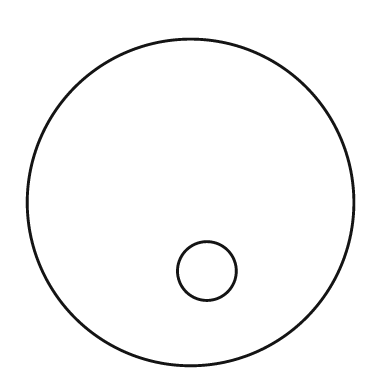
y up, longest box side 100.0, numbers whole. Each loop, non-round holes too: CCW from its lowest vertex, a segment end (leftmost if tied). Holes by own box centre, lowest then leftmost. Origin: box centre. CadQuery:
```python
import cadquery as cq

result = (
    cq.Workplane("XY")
    .moveTo(0.0, 0.0)
    .circle(50.0)
    .moveTo(5.0, -21.0)
    .circle(9.0)
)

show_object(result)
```